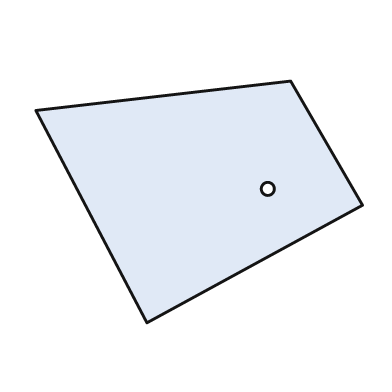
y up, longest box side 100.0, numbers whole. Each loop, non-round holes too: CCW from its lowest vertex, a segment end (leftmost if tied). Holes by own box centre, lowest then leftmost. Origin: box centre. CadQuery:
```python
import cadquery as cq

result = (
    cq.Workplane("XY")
    .moveTo(-16.0, -37.0)
    .lineTo(50.0, -1.0)
    .lineTo(28.0, 37.0)
    .lineTo(-50.0, 28.0)
    .close()
    .moveTo(21.0, 4.0)
    .circle(2.0)
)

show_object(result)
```